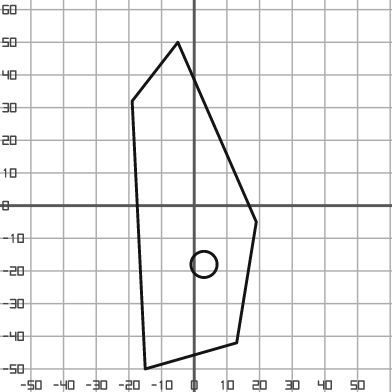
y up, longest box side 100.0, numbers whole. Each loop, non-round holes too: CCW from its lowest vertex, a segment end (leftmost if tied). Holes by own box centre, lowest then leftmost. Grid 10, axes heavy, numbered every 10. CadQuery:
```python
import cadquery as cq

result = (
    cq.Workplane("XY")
    .moveTo(-15.0, -50.0)
    .lineTo(13.0, -42.0)
    .lineTo(19.0, -5.0)
    .lineTo(-5.0, 50.0)
    .lineTo(-19.0, 32.0)
    .close()
    .moveTo(3.0, -18.0)
    .circle(4.0)
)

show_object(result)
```